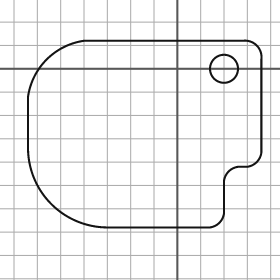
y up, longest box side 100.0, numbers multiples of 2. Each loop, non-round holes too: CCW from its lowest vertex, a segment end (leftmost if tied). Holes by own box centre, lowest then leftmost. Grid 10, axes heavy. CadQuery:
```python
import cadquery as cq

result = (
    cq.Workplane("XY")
    .moveTo(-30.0, -68.0)
    .lineTo(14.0, -68.0)
    .threePointArc((18.0, -66.0), (20.0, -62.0))
    .lineTo(20.0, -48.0)
    .threePointArc((22.0, -44.0), (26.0, -42.0))
    .lineTo(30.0, -42.0)
    .threePointArc((34.0, -40.0), (36.0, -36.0))
    .lineTo(36.0, 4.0)
    .threePointArc((34.0, 10.0), (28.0, 12.0))
    .lineTo(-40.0, 12.0)
    .threePointArc((-56.0, 4.0), (-64.0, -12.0))
    .lineTo(-64.0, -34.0)
    .threePointArc((-54.0, -58.0), (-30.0, -68.0))
    .close()
    .moveTo(20.0, 0.0)
    .circle(6.0)
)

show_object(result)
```